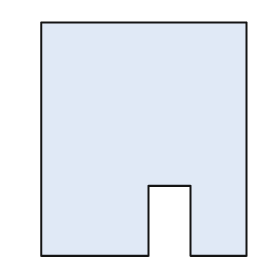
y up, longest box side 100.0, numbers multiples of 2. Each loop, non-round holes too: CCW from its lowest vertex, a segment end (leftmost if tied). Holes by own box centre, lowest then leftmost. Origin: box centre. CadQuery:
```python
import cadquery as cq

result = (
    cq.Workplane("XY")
    .moveTo(-44.0, -50.0)
    .lineTo(2.0, -50.0)
    .lineTo(2.0, -20.0)
    .lineTo(20.0, -20.0)
    .lineTo(20.0, -50.0)
    .lineTo(44.0, -50.0)
    .lineTo(44.0, 50.0)
    .lineTo(-44.0, 50.0)
    .close()
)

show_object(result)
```